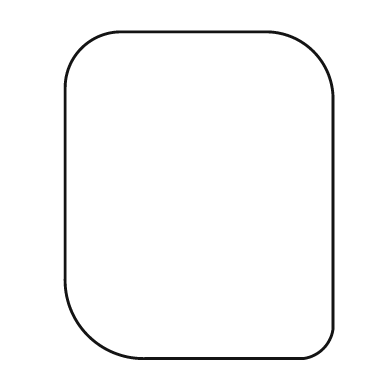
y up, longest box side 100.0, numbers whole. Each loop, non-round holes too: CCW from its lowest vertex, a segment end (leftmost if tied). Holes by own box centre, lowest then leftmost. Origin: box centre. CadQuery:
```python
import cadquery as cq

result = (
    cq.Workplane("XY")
    .moveTo(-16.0, -50.0)
    .lineTo(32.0, -50.0)
    .threePointArc((38.0, -47.0), (41.0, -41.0))
    .lineTo(41.0, 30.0)
    .threePointArc((35.0, 44.0), (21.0, 50.0))
    .lineTo(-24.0, 50.0)
    .threePointArc((-36.0, 45.0), (-41.0, 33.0))
    .lineTo(-41.0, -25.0)
    .threePointArc((-34.0, -43.0), (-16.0, -50.0))
    .close()
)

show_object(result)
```